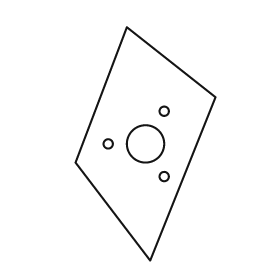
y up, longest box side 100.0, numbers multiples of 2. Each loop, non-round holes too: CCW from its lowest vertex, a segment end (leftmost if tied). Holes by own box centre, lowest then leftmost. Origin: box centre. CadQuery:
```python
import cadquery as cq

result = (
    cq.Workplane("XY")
    .moveTo(2.0, -50.0)
    .lineTo(30.0, 20.0)
    .lineTo(-8.0, 50.0)
    .lineTo(-30.0, -8.0)
    .close()
    .moveTo(8.0, -14.0)
    .circle(2.0)
    .moveTo(-16.0, 0.0)
    .circle(2.0)
    .moveTo(0.0, 0.0)
    .circle(8.0)
    .moveTo(8.0, 14.0)
    .circle(2.0)
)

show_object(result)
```